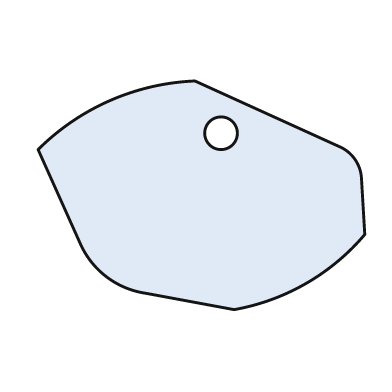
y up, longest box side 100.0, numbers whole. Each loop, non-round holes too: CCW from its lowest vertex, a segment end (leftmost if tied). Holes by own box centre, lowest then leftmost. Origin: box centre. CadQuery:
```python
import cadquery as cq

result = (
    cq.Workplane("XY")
    .moveTo(10.0, -35.0)
    .threePointArc((32.0, -27.0), (50.0, -12.0))
    .lineTo(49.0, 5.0)
    .threePointArc((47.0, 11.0), (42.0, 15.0))
    .lineTo(-2.0, 35.0)
    .threePointArc((-28.0, 29.0), (-50.0, 14.0))
    .lineTo(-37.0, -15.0)
    .threePointArc((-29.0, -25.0), (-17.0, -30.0))
    .close()
    .moveTo(6.0, 19.0)
    .circle(5.0)
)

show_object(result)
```